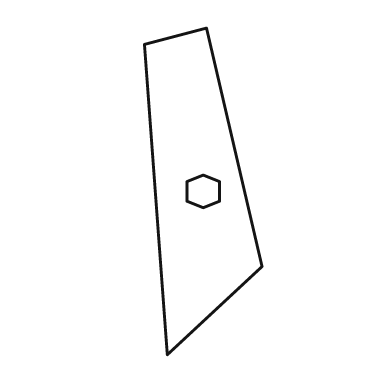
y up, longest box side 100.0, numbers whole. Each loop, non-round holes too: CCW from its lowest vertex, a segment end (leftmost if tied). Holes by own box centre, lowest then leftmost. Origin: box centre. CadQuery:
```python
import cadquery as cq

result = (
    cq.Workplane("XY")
    .moveTo(-11.0, -50.0)
    .lineTo(18.0, -23.0)
    .lineTo(1.0, 50.0)
    .lineTo(-18.0, 45.0)
    .close()
    .moveTo(0.0, -5.0)
    .lineTo(5.0, -3.0)
    .lineTo(5.0, 3.0)
    .lineTo(0.0, 5.0)
    .lineTo(-5.0, 3.0)
    .lineTo(-5.0, -3.0)
    .close()
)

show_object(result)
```